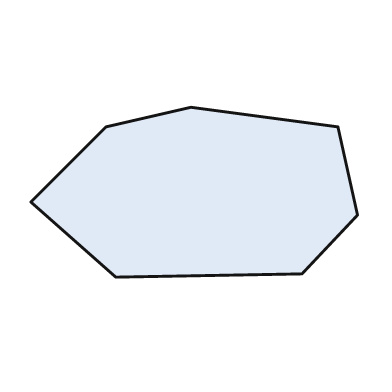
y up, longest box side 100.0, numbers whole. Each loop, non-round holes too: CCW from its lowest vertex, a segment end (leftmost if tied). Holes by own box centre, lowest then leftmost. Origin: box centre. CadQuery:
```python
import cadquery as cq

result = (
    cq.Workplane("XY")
    .moveTo(-24.0, -26.0)
    .lineTo(33.0, -25.0)
    .lineTo(50.0, -7.0)
    .lineTo(44.0, 20.0)
    .lineTo(-1.0, 26.0)
    .lineTo(-27.0, 20.0)
    .lineTo(-50.0, -3.0)
    .close()
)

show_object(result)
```